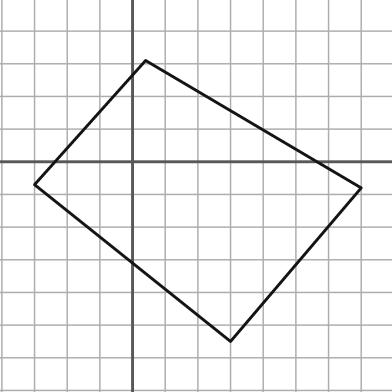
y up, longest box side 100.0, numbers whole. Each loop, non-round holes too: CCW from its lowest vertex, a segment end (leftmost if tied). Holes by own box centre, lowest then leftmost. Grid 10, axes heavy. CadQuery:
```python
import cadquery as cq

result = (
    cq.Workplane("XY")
    .moveTo(30.0, -55.0)
    .lineTo(70.0, -8.0)
    .lineTo(4.0, 31.0)
    .lineTo(-30.0, -7.0)
    .close()
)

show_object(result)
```